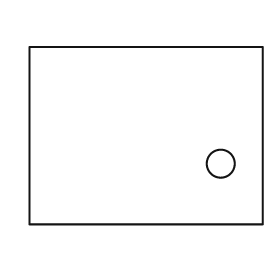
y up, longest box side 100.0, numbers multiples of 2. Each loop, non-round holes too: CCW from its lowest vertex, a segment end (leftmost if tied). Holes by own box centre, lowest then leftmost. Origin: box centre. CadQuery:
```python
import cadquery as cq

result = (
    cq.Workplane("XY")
    .moveTo(-50.0, -38.0)
    .lineTo(50.0, -38.0)
    .lineTo(50.0, 38.0)
    .lineTo(-50.0, 38.0)
    .close()
    .moveTo(32.0, -12.0)
    .circle(6.0)
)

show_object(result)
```